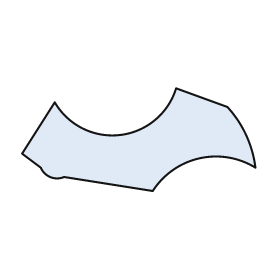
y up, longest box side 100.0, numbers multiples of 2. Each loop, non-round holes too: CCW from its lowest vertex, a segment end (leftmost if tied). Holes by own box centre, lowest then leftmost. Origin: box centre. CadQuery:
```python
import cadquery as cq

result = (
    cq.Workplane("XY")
    .moveTo(6.0, -22.0)
    .threePointArc((26.0, -8.0), (50.0, -12.0))
    .threePointArc((46.0, 2.0), (38.0, 14.0))
    .lineTo(16.0, 22.0)
    .threePointArc((-8.0, 2.0), (-36.0, 16.0))
    .lineTo(-50.0, -6.0)
    .lineTo(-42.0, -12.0)
    .threePointArc((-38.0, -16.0), (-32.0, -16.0))
    .close()
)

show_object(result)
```